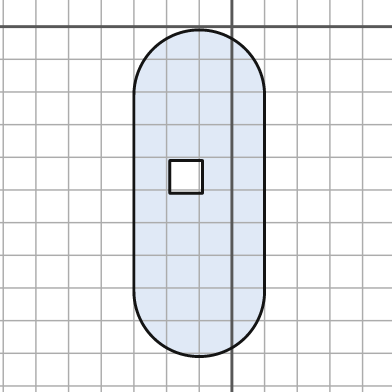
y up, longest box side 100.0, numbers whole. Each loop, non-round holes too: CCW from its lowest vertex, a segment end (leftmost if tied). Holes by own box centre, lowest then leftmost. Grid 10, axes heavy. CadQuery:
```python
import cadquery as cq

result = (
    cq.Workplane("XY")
    .moveTo(-30.0, -81.0)
    .threePointArc((-10.0, -101.0), (10.0, -81.0))
    .lineTo(10.0, -21.0)
    .threePointArc((-10.0, -1.0), (-30.0, -21.0))
    .close()
    .moveTo(-19.0, -51.0)
    .lineTo(-9.0, -51.0)
    .lineTo(-9.0, -41.0)
    .lineTo(-19.0, -41.0)
    .close()
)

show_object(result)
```